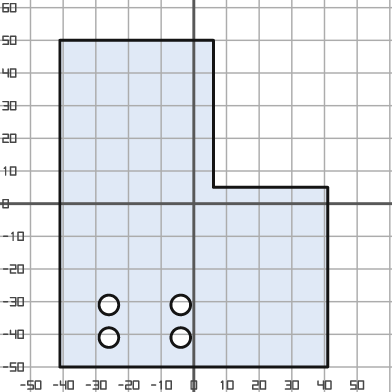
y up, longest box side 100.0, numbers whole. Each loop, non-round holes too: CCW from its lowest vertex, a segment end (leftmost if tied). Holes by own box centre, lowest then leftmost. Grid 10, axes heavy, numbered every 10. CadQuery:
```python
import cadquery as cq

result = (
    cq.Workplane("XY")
    .moveTo(-41.0, -50.0)
    .lineTo(41.0, -50.0)
    .lineTo(41.0, 5.0)
    .lineTo(6.0, 5.0)
    .lineTo(6.0, 50.0)
    .lineTo(-41.0, 50.0)
    .close()
    .moveTo(-26.0, -41.0)
    .circle(3.0)
    .moveTo(-4.0, -41.0)
    .circle(3.0)
    .moveTo(-26.0, -31.0)
    .circle(3.0)
    .moveTo(-4.0, -31.0)
    .circle(3.0)
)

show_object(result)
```